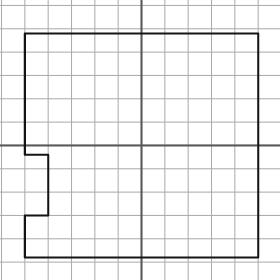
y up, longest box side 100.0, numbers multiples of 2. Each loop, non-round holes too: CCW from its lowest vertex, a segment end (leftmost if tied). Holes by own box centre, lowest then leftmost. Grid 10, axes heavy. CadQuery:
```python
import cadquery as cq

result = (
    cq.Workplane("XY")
    .moveTo(-50.0, -48.0)
    .lineTo(50.0, -48.0)
    .lineTo(50.0, 48.0)
    .lineTo(-50.0, 48.0)
    .lineTo(-50.0, -4.0)
    .lineTo(-40.0, -4.0)
    .lineTo(-40.0, -30.0)
    .lineTo(-50.0, -30.0)
    .close()
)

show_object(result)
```